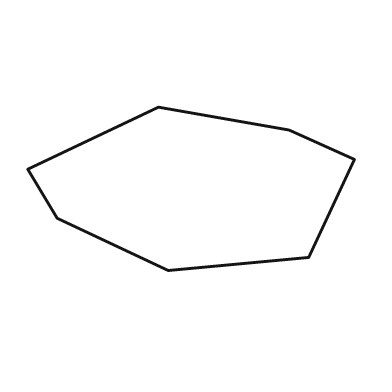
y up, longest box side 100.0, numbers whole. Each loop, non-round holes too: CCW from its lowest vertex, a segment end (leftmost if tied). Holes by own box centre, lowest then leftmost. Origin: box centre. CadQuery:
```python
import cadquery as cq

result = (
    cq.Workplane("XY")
    .moveTo(-7.0, -25.0)
    .lineTo(36.0, -21.0)
    .lineTo(50.0, 9.0)
    .lineTo(30.0, 18.0)
    .lineTo(-10.0, 25.0)
    .lineTo(-50.0, 6.0)
    .lineTo(-41.0, -9.0)
    .close()
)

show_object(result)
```